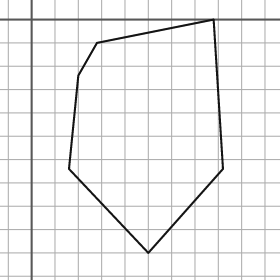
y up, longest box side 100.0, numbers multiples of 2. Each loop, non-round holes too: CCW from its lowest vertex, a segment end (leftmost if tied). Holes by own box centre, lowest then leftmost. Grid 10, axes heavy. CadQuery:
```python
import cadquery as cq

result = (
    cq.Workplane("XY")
    .moveTo(50.0, -100.0)
    .lineTo(82.0, -64.0)
    .lineTo(78.0, 0.0)
    .lineTo(28.0, -10.0)
    .lineTo(20.0, -24.0)
    .lineTo(16.0, -64.0)
    .close()
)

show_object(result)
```